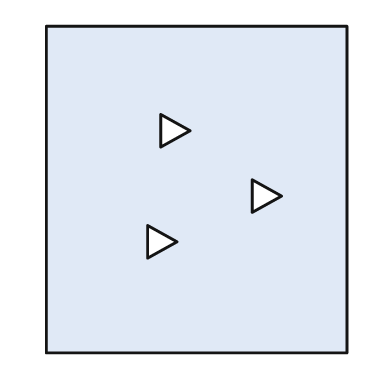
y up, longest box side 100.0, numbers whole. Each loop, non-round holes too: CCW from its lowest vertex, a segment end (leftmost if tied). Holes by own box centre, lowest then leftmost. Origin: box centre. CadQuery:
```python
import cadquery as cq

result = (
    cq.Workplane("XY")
    .moveTo(-46.0, -50.0)
    .lineTo(46.0, -50.0)
    .lineTo(46.0, 50.0)
    .lineTo(-46.0, 50.0)
    .close()
    .moveTo(-15.0, -21.0)
    .lineTo(-6.0, -16.0)
    .lineTo(-15.0, -11.0)
    .close()
    .moveTo(17.0, -7.0)
    .lineTo(26.0, -2.0)
    .lineTo(17.0, 3.0)
    .close()
    .moveTo(-11.0, 13.0)
    .lineTo(-2.0, 18.0)
    .lineTo(-11.0, 23.0)
    .close()
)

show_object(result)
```